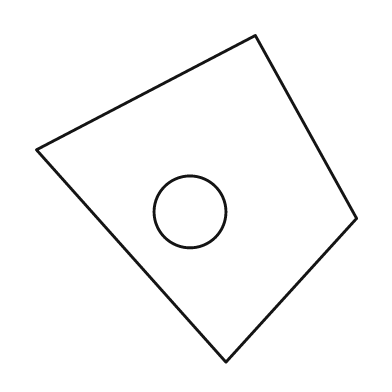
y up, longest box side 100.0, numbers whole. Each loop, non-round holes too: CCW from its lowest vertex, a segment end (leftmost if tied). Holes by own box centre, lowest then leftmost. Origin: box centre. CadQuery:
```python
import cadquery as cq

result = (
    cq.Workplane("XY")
    .moveTo(9.0, -50.0)
    .lineTo(49.0, -6.0)
    .lineTo(18.0, 50.0)
    .lineTo(-49.0, 15.0)
    .close()
    .moveTo(-2.0, -4.0)
    .circle(11.0)
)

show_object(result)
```